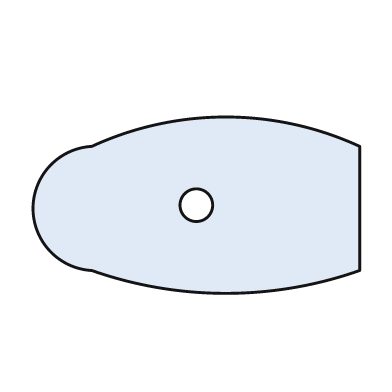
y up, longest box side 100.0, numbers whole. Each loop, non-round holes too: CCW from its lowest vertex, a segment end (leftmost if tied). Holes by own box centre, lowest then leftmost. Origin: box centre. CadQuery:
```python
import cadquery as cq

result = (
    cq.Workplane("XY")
    .moveTo(-32.0, -20.0)
    .threePointArc((9.0, -27.0), (50.0, -20.0))
    .lineTo(50.0, 18.0)
    .threePointArc((9.0, 27.0), (-32.0, 18.0))
    .threePointArc((-50.0, -1.0), (-32.0, -20.0))
    .close()
    .moveTo(0.0, 0.0)
    .circle(5.0)
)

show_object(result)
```